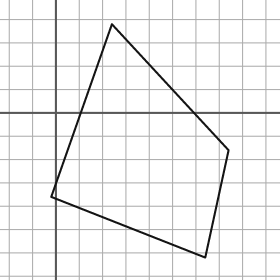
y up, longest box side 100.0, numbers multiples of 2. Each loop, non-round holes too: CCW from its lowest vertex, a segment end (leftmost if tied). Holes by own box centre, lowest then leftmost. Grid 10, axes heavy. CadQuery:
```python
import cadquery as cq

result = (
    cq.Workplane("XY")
    .moveTo(64.0, -62.0)
    .lineTo(74.0, -16.0)
    .lineTo(24.0, 38.0)
    .lineTo(-2.0, -36.0)
    .close()
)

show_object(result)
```